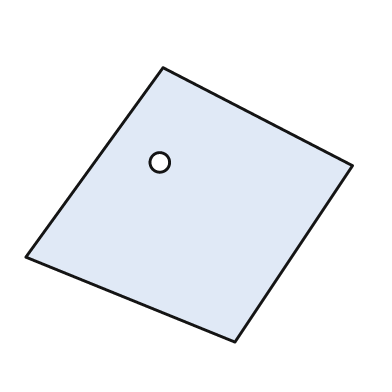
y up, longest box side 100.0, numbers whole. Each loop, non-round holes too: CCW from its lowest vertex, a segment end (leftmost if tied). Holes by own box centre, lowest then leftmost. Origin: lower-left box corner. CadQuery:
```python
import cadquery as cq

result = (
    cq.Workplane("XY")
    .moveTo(64.0, 0.0)
    .lineTo(100.0, 54.0)
    .lineTo(42.0, 84.0)
    .lineTo(0.0, 26.0)
    .close()
    .moveTo(41.0, 55.0)
    .circle(3.0)
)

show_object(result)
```